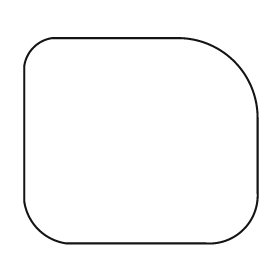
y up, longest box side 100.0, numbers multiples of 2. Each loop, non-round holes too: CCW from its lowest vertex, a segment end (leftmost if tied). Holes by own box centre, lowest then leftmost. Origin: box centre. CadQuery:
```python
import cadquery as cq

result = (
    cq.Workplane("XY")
    .moveTo(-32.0, -44.0)
    .lineTo(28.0, -44.0)
    .threePointArc((44.0, -38.0), (50.0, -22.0))
    .lineTo(50.0, 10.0)
    .threePointArc((40.0, 34.0), (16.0, 44.0))
    .lineTo(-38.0, 44.0)
    .threePointArc((-46.0, 40.0), (-50.0, 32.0))
    .lineTo(-50.0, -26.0)
    .threePointArc((-44.0, -38.0), (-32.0, -44.0))
    .close()
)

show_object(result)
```